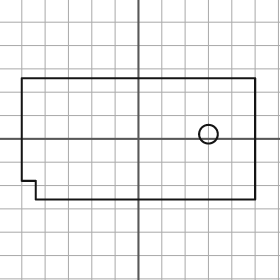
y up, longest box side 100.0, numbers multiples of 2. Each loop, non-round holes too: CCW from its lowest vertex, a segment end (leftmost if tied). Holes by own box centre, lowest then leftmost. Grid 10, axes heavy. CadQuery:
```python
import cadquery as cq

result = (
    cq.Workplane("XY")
    .moveTo(-44.0, -26.0)
    .lineTo(50.0, -26.0)
    .lineTo(50.0, 26.0)
    .lineTo(-50.0, 26.0)
    .lineTo(-50.0, -18.0)
    .lineTo(-44.0, -18.0)
    .close()
    .moveTo(30.0, 2.0)
    .circle(4.0)
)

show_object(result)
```